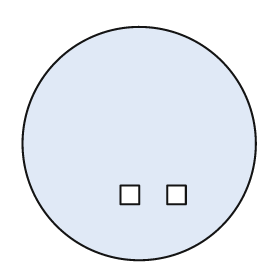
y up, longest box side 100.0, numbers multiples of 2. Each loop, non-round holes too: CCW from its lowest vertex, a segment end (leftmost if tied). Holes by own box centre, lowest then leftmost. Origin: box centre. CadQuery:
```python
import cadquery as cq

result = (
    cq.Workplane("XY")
    .moveTo(0.0, 0.0)
    .circle(50.0)
    .moveTo(-8.0, -26.0)
    .lineTo(0.0, -26.0)
    .lineTo(0.0, -18.0)
    .lineTo(-8.0, -18.0)
    .close()
    .moveTo(12.0, -26.0)
    .lineTo(20.0, -26.0)
    .lineTo(20.0, -18.0)
    .lineTo(12.0, -18.0)
    .close()
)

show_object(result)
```